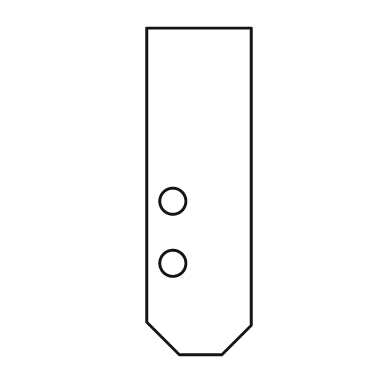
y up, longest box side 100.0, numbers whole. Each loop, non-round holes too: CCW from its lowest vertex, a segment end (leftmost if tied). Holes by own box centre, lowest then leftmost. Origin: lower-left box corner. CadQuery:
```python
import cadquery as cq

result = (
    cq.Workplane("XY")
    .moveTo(10.0, 0.0)
    .lineTo(23.0, 0.0)
    .lineTo(32.0, 9.0)
    .lineTo(32.0, 100.0)
    .lineTo(0.0, 100.0)
    .lineTo(0.0, 10.0)
    .close()
    .moveTo(8.0, 28.0)
    .circle(4.0)
    .moveTo(8.0, 47.0)
    .circle(4.0)
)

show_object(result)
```